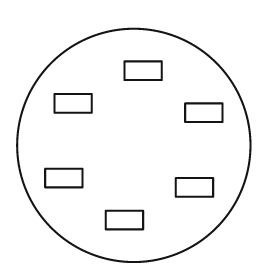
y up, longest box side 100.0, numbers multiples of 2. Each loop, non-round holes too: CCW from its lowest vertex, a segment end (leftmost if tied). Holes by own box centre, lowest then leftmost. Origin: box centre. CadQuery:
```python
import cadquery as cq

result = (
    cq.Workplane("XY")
    .moveTo(0.0, 0.0)
    .circle(50.0)
    .moveTo(-12.0, -36.0)
    .lineTo(4.0, -36.0)
    .lineTo(4.0, -28.0)
    .lineTo(-12.0, -28.0)
    .close()
    .moveTo(18.0, -22.0)
    .lineTo(34.0, -22.0)
    .lineTo(34.0, -14.0)
    .lineTo(18.0, -14.0)
    .close()
    .moveTo(-38.0, -18.0)
    .lineTo(-22.0, -18.0)
    .lineTo(-22.0, -10.0)
    .lineTo(-38.0, -10.0)
    .close()
    .moveTo(22.0, 10.0)
    .lineTo(38.0, 10.0)
    .lineTo(38.0, 18.0)
    .lineTo(22.0, 18.0)
    .close()
    .moveTo(-34.0, 14.0)
    .lineTo(-18.0, 14.0)
    .lineTo(-18.0, 22.0)
    .lineTo(-34.0, 22.0)
    .close()
    .moveTo(-4.0, 28.0)
    .lineTo(12.0, 28.0)
    .lineTo(12.0, 36.0)
    .lineTo(-4.0, 36.0)
    .close()
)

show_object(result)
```